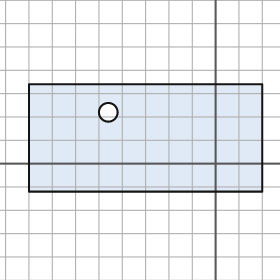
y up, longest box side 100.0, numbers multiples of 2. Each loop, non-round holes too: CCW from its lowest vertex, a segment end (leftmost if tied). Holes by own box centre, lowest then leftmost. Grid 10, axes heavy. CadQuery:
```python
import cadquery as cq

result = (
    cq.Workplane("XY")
    .moveTo(-80.0, -12.0)
    .lineTo(20.0, -12.0)
    .lineTo(20.0, 34.0)
    .lineTo(-80.0, 34.0)
    .close()
    .moveTo(-46.0, 22.0)
    .circle(4.0)
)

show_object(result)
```